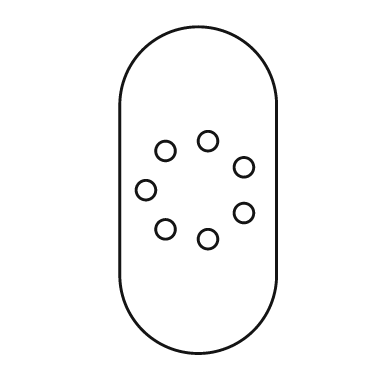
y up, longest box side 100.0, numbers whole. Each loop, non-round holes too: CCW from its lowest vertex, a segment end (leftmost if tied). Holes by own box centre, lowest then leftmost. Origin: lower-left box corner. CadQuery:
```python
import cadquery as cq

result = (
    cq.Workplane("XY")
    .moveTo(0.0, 24.0)
    .threePointArc((24.0, 0.0), (48.0, 24.0))
    .lineTo(48.0, 76.0)
    .threePointArc((24.0, 100.0), (0.0, 76.0))
    .close()
    .moveTo(27.0, 35.0)
    .circle(3.0)
    .moveTo(14.0, 38.0)
    .circle(3.0)
    .moveTo(38.0, 43.0)
    .circle(3.0)
    .moveTo(8.0, 50.0)
    .circle(3.0)
    .moveTo(38.0, 57.0)
    .circle(3.0)
    .moveTo(14.0, 62.0)
    .circle(3.0)
    .moveTo(27.0, 65.0)
    .circle(3.0)
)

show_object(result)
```